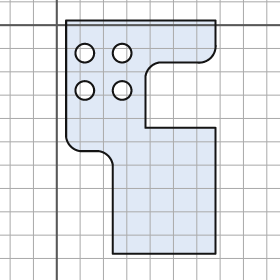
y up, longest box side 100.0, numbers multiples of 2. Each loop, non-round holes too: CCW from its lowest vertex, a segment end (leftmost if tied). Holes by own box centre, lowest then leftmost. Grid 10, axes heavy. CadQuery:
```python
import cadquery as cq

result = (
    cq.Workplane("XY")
    .moveTo(24.0, -98.0)
    .lineTo(68.0, -98.0)
    .lineTo(68.0, -44.0)
    .lineTo(38.0, -44.0)
    .lineTo(38.0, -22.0)
    .threePointArc((40.0, -18.0), (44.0, -16.0))
    .lineTo(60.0, -16.0)
    .threePointArc((66.0, -14.0), (68.0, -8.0))
    .lineTo(68.0, 2.0)
    .lineTo(4.0, 2.0)
    .lineTo(4.0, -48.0)
    .threePointArc((6.0, -52.0), (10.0, -54.0))
    .lineTo(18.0, -54.0)
    .threePointArc((22.0, -56.0), (24.0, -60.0))
    .close()
    .moveTo(12.0, -28.0)
    .circle(4.0)
    .moveTo(28.0, -28.0)
    .circle(4.0)
    .moveTo(12.0, -12.0)
    .circle(4.0)
    .moveTo(28.0, -12.0)
    .circle(4.0)
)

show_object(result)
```